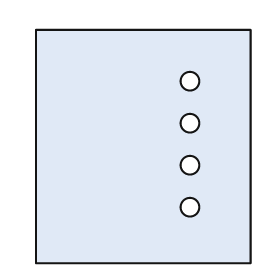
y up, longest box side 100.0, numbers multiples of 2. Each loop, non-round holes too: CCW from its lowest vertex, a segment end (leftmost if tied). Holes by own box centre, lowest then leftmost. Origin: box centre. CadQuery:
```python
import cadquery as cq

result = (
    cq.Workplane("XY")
    .moveTo(-46.0, -50.0)
    .lineTo(46.0, -50.0)
    .lineTo(46.0, 50.0)
    .lineTo(-46.0, 50.0)
    .close()
    .moveTo(20.0, -26.0)
    .circle(4.0)
    .moveTo(20.0, -8.0)
    .circle(4.0)
    .moveTo(20.0, 10.0)
    .circle(4.0)
    .moveTo(20.0, 28.0)
    .circle(4.0)
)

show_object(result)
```